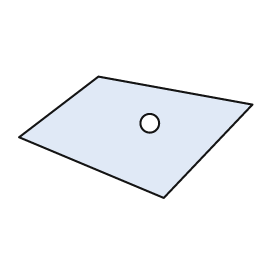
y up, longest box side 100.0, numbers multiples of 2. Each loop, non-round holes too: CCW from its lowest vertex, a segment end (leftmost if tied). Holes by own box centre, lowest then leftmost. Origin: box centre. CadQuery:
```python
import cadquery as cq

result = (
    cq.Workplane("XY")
    .moveTo(12.0, -26.0)
    .lineTo(50.0, 14.0)
    .lineTo(-16.0, 26.0)
    .lineTo(-50.0, 0.0)
    .close()
    .moveTo(6.0, 6.0)
    .circle(4.0)
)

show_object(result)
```